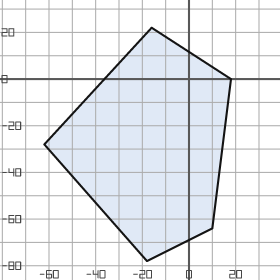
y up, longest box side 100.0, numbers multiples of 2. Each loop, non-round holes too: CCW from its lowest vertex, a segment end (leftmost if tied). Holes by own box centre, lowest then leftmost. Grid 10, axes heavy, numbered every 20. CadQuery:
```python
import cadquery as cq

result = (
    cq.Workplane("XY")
    .moveTo(-18.0, -78.0)
    .lineTo(10.0, -64.0)
    .lineTo(18.0, 0.0)
    .lineTo(-16.0, 22.0)
    .lineTo(-62.0, -28.0)
    .close()
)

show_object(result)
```